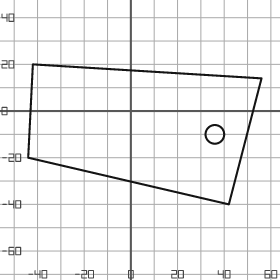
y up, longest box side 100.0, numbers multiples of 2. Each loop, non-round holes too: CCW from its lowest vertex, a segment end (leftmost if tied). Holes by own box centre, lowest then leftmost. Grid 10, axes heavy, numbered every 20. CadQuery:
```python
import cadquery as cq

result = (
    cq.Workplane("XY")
    .moveTo(42.0, -40.0)
    .lineTo(56.0, 14.0)
    .lineTo(-42.0, 20.0)
    .lineTo(-44.0, -20.0)
    .close()
    .moveTo(36.0, -10.0)
    .circle(4.0)
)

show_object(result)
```